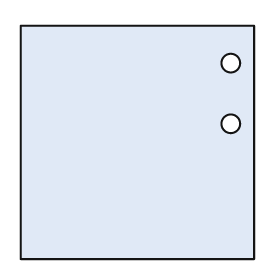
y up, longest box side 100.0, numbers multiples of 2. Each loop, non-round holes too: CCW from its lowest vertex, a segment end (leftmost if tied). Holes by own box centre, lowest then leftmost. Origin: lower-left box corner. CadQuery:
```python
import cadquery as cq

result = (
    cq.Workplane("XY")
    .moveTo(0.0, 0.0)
    .lineTo(100.0, 0.0)
    .lineTo(100.0, 100.0)
    .lineTo(0.0, 100.0)
    .close()
    .moveTo(90.0, 58.0)
    .circle(4.0)
    .moveTo(90.0, 84.0)
    .circle(4.0)
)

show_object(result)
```